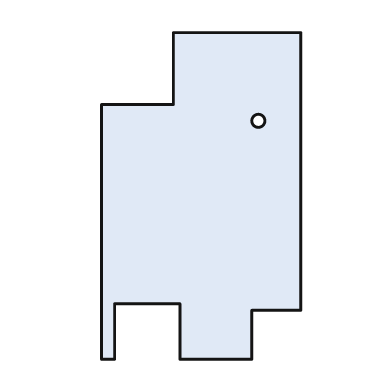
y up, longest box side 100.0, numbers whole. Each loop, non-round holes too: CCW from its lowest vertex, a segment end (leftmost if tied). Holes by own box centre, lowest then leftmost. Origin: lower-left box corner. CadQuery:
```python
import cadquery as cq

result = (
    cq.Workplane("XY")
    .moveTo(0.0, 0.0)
    .lineTo(4.0, 0.0)
    .lineTo(4.0, 17.0)
    .lineTo(24.0, 17.0)
    .lineTo(24.0, 0.0)
    .lineTo(46.0, 0.0)
    .lineTo(46.0, 15.0)
    .lineTo(61.0, 15.0)
    .lineTo(61.0, 100.0)
    .lineTo(22.0, 100.0)
    .lineTo(22.0, 78.0)
    .lineTo(0.0, 78.0)
    .close()
    .moveTo(48.0, 73.0)
    .circle(2.0)
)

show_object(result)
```